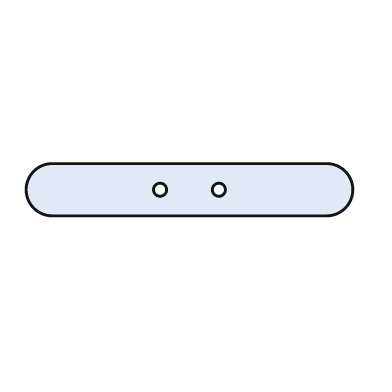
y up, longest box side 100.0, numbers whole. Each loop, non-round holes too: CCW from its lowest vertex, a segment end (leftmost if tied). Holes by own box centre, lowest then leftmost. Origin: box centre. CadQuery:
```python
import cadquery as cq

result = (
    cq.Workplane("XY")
    .moveTo(-42.0, -8.0)
    .lineTo(42.0, -8.0)
    .threePointArc((50.0, 0.0), (42.0, 8.0))
    .lineTo(-42.0, 8.0)
    .threePointArc((-50.0, 0.0), (-42.0, -8.0))
    .close()
    .moveTo(-9.0, 0.0)
    .circle(2.0)
    .moveTo(9.0, 0.0)
    .circle(2.0)
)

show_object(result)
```